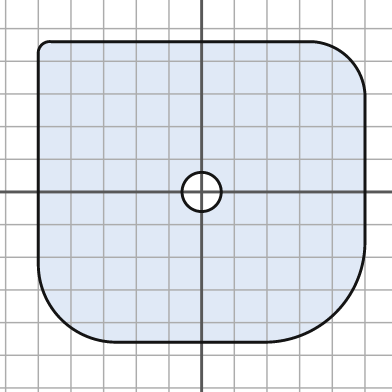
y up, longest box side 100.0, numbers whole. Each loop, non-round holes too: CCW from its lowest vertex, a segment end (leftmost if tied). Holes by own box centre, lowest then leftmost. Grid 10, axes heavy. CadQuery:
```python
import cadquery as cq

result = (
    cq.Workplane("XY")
    .moveTo(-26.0, -46.0)
    .lineTo(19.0, -46.0)
    .threePointArc((41.0, -37.0), (50.0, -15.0))
    .lineTo(50.0, 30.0)
    .threePointArc((45.0, 41.0), (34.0, 46.0))
    .lineTo(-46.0, 46.0)
    .threePointArc((-49.0, 45.0), (-50.0, 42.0))
    .lineTo(-50.0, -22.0)
    .threePointArc((-43.0, -39.0), (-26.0, -46.0))
    .close()
    .moveTo(0.0, 0.0)
    .circle(6.0)
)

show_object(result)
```